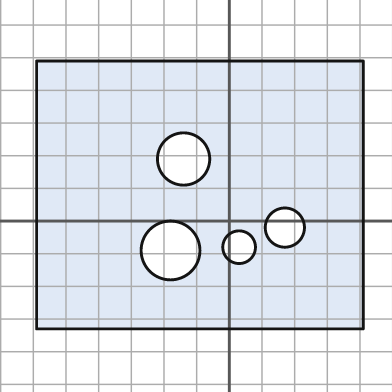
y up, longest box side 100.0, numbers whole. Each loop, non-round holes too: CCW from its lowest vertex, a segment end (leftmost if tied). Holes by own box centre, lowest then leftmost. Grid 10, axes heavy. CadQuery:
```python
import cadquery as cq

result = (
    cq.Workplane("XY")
    .moveTo(-59.0, -33.0)
    .lineTo(41.0, -33.0)
    .lineTo(41.0, 49.0)
    .lineTo(-59.0, 49.0)
    .close()
    .moveTo(-18.0, -9.0)
    .circle(9.0)
    .moveTo(3.0, -8.0)
    .circle(5.0)
    .moveTo(17.0, -2.0)
    .circle(6.0)
    .moveTo(-14.0, 19.0)
    .circle(8.0)
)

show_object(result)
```